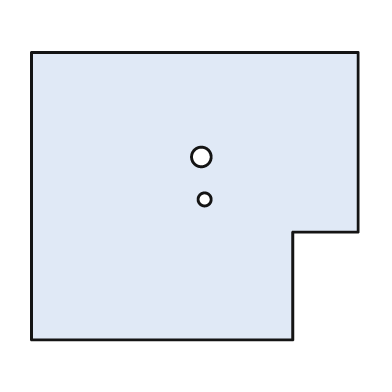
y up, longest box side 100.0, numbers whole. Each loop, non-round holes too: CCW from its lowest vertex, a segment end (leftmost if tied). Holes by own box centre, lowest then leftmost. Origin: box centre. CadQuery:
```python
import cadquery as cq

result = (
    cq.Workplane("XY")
    .moveTo(-50.0, -44.0)
    .lineTo(30.0, -44.0)
    .lineTo(30.0, -11.0)
    .lineTo(50.0, -11.0)
    .lineTo(50.0, 44.0)
    .lineTo(-50.0, 44.0)
    .close()
    .moveTo(3.0, -1.0)
    .circle(2.0)
    .moveTo(2.0, 12.0)
    .circle(3.0)
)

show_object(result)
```